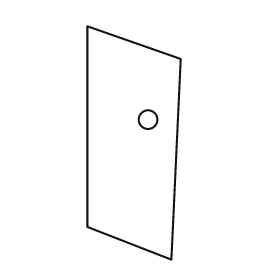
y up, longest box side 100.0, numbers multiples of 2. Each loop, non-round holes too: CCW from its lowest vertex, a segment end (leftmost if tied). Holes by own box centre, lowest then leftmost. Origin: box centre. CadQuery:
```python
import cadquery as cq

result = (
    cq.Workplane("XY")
    .moveTo(16.0, -50.0)
    .lineTo(20.0, 36.0)
    .lineTo(-20.0, 50.0)
    .lineTo(-20.0, -36.0)
    .close()
    .moveTo(6.0, 10.0)
    .circle(4.0)
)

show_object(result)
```